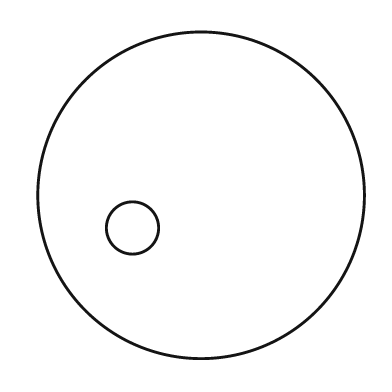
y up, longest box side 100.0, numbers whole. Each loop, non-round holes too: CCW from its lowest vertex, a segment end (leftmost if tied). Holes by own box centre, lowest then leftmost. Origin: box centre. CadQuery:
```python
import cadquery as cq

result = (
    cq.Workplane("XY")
    .moveTo(0.0, 0.0)
    .circle(50.0)
    .moveTo(-21.0, -10.0)
    .circle(8.0)
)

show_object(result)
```